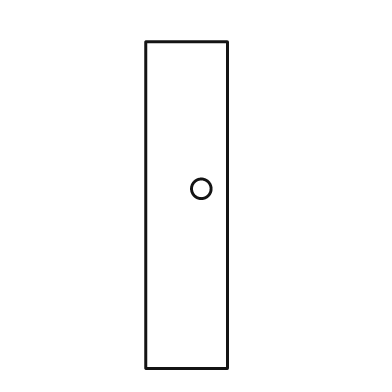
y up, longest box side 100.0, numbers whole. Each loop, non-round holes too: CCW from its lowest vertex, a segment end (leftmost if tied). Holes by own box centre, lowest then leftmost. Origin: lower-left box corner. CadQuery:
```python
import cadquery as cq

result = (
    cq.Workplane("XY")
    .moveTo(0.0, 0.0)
    .lineTo(25.0, 0.0)
    .lineTo(25.0, 100.0)
    .lineTo(0.0, 100.0)
    .close()
    .moveTo(17.0, 55.0)
    .circle(3.0)
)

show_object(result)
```